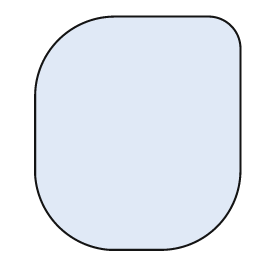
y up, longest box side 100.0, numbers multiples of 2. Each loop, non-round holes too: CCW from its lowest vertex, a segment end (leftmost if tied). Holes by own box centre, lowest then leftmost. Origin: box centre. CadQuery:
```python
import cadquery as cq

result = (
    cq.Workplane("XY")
    .moveTo(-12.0, -50.0)
    .lineTo(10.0, -50.0)
    .threePointArc((34.0, -40.0), (44.0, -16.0))
    .lineTo(44.0, 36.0)
    .threePointArc((40.0, 46.0), (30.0, 50.0))
    .lineTo(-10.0, 50.0)
    .threePointArc((-34.0, 40.0), (-44.0, 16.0))
    .lineTo(-44.0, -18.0)
    .threePointArc((-34.0, -40.0), (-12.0, -50.0))
    .close()
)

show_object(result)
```